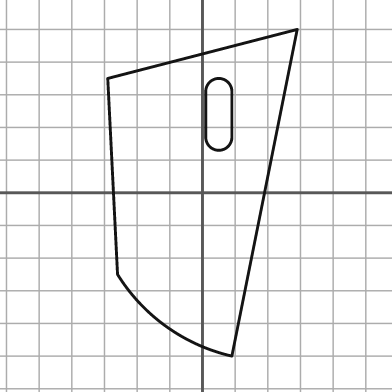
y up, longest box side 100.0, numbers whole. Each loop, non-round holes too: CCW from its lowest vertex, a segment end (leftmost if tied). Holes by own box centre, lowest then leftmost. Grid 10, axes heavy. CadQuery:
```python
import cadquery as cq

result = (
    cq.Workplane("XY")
    .moveTo(9.0, -50.0)
    .lineTo(29.0, 50.0)
    .lineTo(-29.0, 35.0)
    .lineTo(-26.0, -25.0)
    .threePointArc((-11.0, -41.0), (9.0, -50.0))
    .close()
    .moveTo(1.0, 17.0)
    .threePointArc((5.0, 13.0), (9.0, 17.0))
    .lineTo(9.0, 31.0)
    .threePointArc((5.0, 35.0), (1.0, 31.0))
    .close()
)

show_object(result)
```